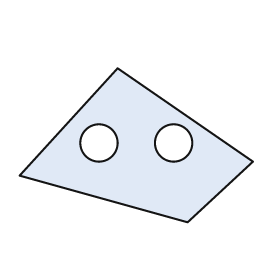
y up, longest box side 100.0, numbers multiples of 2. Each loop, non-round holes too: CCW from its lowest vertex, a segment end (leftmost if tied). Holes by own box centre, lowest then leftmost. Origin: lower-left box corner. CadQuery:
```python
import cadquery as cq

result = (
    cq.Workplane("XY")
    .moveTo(72.0, 0.0)
    .lineTo(100.0, 26.0)
    .lineTo(42.0, 66.0)
    .lineTo(0.0, 20.0)
    .close()
    .moveTo(34.0, 34.0)
    .circle(8.0)
    .moveTo(66.0, 34.0)
    .circle(8.0)
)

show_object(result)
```